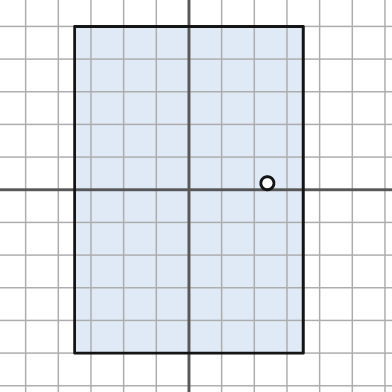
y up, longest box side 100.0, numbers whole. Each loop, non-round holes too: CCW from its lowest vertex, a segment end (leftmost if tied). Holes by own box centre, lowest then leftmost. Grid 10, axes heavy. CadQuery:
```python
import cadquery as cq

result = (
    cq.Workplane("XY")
    .moveTo(-35.0, -50.0)
    .lineTo(35.0, -50.0)
    .lineTo(35.0, 50.0)
    .lineTo(-35.0, 50.0)
    .close()
    .moveTo(24.0, 2.0)
    .circle(2.0)
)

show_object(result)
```